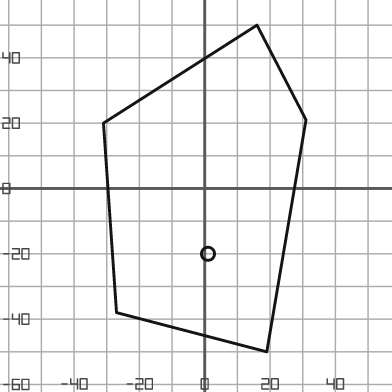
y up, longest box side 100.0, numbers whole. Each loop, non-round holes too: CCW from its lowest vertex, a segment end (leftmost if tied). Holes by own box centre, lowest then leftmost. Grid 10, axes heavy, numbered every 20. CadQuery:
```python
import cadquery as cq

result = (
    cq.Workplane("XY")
    .moveTo(19.0, -50.0)
    .lineTo(31.0, 21.0)
    .lineTo(16.0, 50.0)
    .lineTo(-31.0, 20.0)
    .lineTo(-27.0, -38.0)
    .close()
    .moveTo(1.0, -20.0)
    .circle(2.0)
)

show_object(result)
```